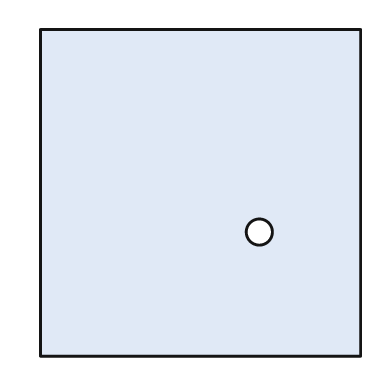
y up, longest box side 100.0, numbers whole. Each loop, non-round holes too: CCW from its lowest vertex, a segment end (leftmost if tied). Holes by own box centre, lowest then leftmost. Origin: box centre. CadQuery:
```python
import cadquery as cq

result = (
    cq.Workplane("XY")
    .moveTo(-49.0, -50.0)
    .lineTo(49.0, -50.0)
    .lineTo(49.0, 50.0)
    .lineTo(-49.0, 50.0)
    .close()
    .moveTo(18.0, -12.0)
    .circle(4.0)
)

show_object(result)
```